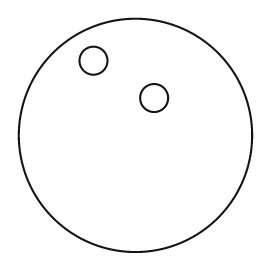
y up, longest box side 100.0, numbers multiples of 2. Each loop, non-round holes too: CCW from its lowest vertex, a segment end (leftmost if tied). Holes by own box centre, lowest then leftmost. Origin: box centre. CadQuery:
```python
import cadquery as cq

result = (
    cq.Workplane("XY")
    .moveTo(0.0, 0.0)
    .circle(50.0)
    .moveTo(8.0, 16.0)
    .circle(6.0)
    .moveTo(-18.0, 32.0)
    .circle(6.0)
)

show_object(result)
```